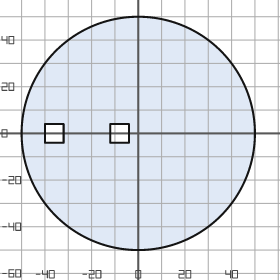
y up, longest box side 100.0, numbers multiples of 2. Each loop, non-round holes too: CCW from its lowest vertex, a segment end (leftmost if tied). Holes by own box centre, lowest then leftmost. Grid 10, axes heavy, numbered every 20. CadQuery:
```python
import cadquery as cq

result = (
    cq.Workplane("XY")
    .moveTo(0.0, 0.0)
    .circle(50.0)
    .moveTo(-40.0, -4.0)
    .lineTo(-32.0, -4.0)
    .lineTo(-32.0, 4.0)
    .lineTo(-40.0, 4.0)
    .close()
    .moveTo(-12.0, -4.0)
    .lineTo(-4.0, -4.0)
    .lineTo(-4.0, 4.0)
    .lineTo(-12.0, 4.0)
    .close()
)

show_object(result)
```